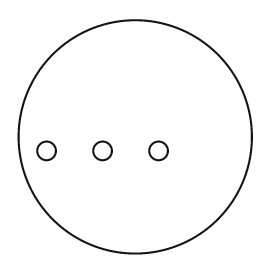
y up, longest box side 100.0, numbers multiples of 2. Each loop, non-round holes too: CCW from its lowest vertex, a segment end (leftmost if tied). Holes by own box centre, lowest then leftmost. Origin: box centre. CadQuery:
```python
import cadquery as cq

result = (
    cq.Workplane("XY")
    .moveTo(0.0, 0.0)
    .circle(50.0)
    .moveTo(-38.0, -6.0)
    .circle(4.0)
    .moveTo(-14.0, -6.0)
    .circle(4.0)
    .moveTo(10.0, -6.0)
    .circle(4.0)
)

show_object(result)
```